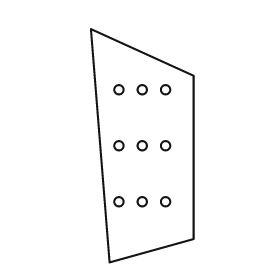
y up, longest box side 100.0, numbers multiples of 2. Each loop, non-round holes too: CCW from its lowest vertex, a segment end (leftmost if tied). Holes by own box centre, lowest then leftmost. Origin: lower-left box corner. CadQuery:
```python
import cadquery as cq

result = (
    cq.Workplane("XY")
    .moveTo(8.0, 0.0)
    .lineTo(44.0, 10.0)
    .lineTo(44.0, 80.0)
    .lineTo(0.0, 100.0)
    .close()
    .moveTo(12.0, 26.0)
    .circle(2.0)
    .moveTo(22.0, 26.0)
    .circle(2.0)
    .moveTo(32.0, 26.0)
    .circle(2.0)
    .moveTo(12.0, 50.0)
    .circle(2.0)
    .moveTo(22.0, 50.0)
    .circle(2.0)
    .moveTo(32.0, 50.0)
    .circle(2.0)
    .moveTo(12.0, 74.0)
    .circle(2.0)
    .moveTo(22.0, 74.0)
    .circle(2.0)
    .moveTo(32.0, 74.0)
    .circle(2.0)
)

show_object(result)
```